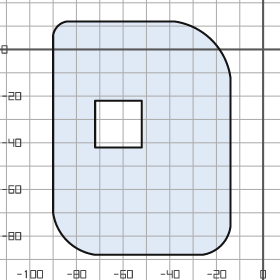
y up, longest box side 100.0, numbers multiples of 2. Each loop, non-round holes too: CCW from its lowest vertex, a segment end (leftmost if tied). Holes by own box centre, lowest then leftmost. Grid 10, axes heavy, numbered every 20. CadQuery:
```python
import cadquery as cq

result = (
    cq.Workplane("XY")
    .moveTo(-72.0, -88.0)
    .lineTo(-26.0, -88.0)
    .threePointArc((-18.0, -84.0), (-14.0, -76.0))
    .lineTo(-14.0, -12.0)
    .threePointArc((-22.0, 4.0), (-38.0, 12.0))
    .lineTo(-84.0, 12.0)
    .threePointArc((-88.0, 10.0), (-90.0, 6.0))
    .lineTo(-90.0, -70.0)
    .threePointArc((-84.0, -82.0), (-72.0, -88.0))
    .close()
    .moveTo(-72.0, -42.0)
    .lineTo(-52.0, -42.0)
    .lineTo(-52.0, -22.0)
    .lineTo(-72.0, -22.0)
    .close()
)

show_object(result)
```